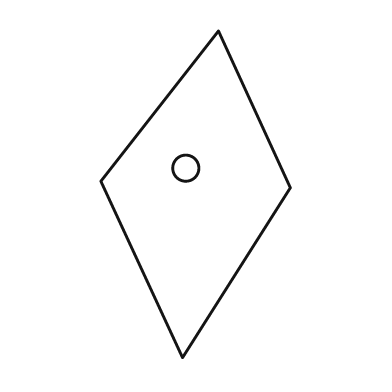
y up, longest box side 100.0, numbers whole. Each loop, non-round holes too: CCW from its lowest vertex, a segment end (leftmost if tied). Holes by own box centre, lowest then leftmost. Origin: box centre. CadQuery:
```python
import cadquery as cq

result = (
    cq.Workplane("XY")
    .moveTo(-4.0, -50.0)
    .lineTo(29.0, 2.0)
    .lineTo(7.0, 50.0)
    .lineTo(-29.0, 4.0)
    .close()
    .moveTo(-3.0, 8.0)
    .circle(4.0)
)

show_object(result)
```